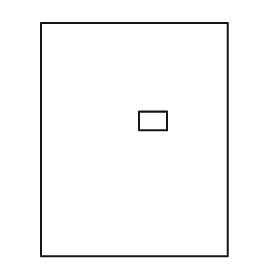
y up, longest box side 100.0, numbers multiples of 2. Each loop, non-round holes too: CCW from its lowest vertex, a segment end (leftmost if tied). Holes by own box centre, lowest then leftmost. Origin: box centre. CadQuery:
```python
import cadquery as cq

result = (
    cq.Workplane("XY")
    .moveTo(-40.0, -50.0)
    .lineTo(40.0, -50.0)
    .lineTo(40.0, 50.0)
    .lineTo(-40.0, 50.0)
    .close()
    .moveTo(2.0, 4.0)
    .lineTo(14.0, 4.0)
    .lineTo(14.0, 12.0)
    .lineTo(2.0, 12.0)
    .close()
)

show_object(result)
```